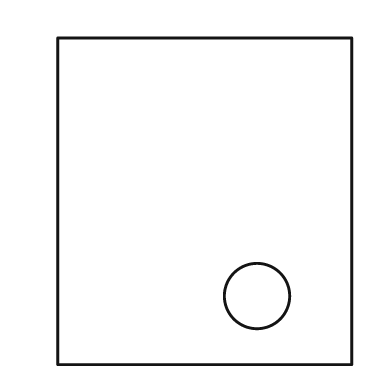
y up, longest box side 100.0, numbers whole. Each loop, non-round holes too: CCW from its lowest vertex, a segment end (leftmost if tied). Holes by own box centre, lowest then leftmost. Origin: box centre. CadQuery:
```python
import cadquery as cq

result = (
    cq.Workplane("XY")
    .moveTo(-45.0, -50.0)
    .lineTo(45.0, -50.0)
    .lineTo(45.0, 50.0)
    .lineTo(-45.0, 50.0)
    .close()
    .moveTo(16.0, -29.0)
    .circle(10.0)
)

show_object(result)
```